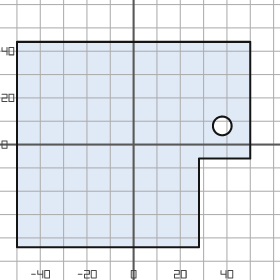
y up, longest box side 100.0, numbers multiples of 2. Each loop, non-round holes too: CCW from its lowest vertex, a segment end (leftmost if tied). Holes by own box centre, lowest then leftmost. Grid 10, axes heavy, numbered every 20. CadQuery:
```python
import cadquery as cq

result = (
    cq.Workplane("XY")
    .moveTo(-50.0, -44.0)
    .lineTo(28.0, -44.0)
    .lineTo(28.0, -6.0)
    .lineTo(50.0, -6.0)
    .lineTo(50.0, 44.0)
    .lineTo(-50.0, 44.0)
    .close()
    .moveTo(38.0, 8.0)
    .circle(4.0)
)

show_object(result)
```